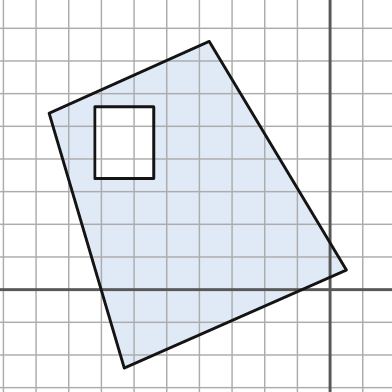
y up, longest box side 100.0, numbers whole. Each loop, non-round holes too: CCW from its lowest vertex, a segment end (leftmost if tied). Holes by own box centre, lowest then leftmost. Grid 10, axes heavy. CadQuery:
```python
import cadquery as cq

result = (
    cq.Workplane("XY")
    .moveTo(-63.0, -24.0)
    .lineTo(5.0, 6.0)
    .lineTo(-37.0, 76.0)
    .lineTo(-86.0, 54.0)
    .close()
    .moveTo(-72.0, 34.0)
    .lineTo(-54.0, 34.0)
    .lineTo(-54.0, 56.0)
    .lineTo(-72.0, 56.0)
    .close()
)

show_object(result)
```